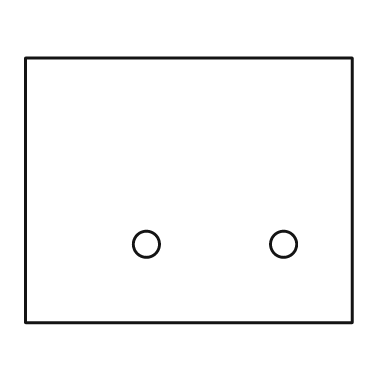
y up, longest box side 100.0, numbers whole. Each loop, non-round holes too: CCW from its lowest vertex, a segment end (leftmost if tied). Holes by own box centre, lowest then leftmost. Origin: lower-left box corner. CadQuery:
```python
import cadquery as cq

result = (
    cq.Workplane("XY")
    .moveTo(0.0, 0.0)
    .lineTo(100.0, 0.0)
    .lineTo(100.0, 81.0)
    .lineTo(0.0, 81.0)
    .close()
    .moveTo(37.0, 24.0)
    .circle(4.0)
    .moveTo(79.0, 24.0)
    .circle(4.0)
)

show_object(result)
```